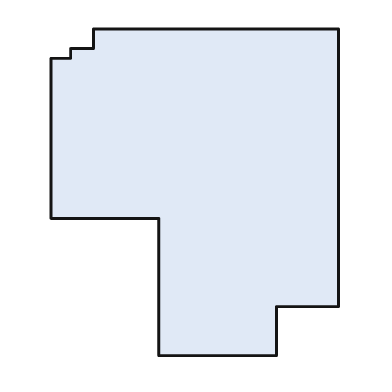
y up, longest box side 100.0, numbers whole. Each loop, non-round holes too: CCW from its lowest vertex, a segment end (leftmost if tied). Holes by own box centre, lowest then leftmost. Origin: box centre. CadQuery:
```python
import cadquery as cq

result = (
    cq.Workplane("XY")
    .moveTo(-11.0, -50.0)
    .lineTo(25.0, -50.0)
    .lineTo(25.0, -35.0)
    .lineTo(44.0, -35.0)
    .lineTo(44.0, 50.0)
    .lineTo(-31.0, 50.0)
    .lineTo(-31.0, 44.0)
    .lineTo(-38.0, 44.0)
    .lineTo(-38.0, 41.0)
    .lineTo(-44.0, 41.0)
    .lineTo(-44.0, -8.0)
    .lineTo(-11.0, -8.0)
    .close()
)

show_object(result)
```